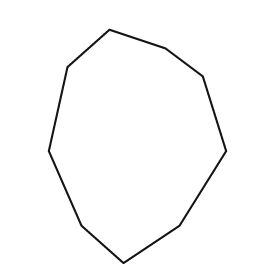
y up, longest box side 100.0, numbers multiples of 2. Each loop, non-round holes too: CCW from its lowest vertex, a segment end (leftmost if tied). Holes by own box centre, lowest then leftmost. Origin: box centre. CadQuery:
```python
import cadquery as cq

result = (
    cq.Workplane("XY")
    .moveTo(-6.0, -50.0)
    .lineTo(18.0, -34.0)
    .lineTo(38.0, -2.0)
    .lineTo(28.0, 30.0)
    .lineTo(12.0, 42.0)
    .lineTo(-12.0, 50.0)
    .lineTo(-30.0, 34.0)
    .lineTo(-38.0, -2.0)
    .lineTo(-24.0, -34.0)
    .close()
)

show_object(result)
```